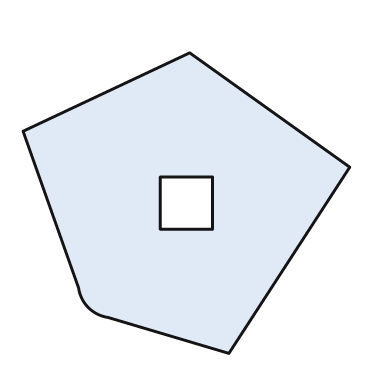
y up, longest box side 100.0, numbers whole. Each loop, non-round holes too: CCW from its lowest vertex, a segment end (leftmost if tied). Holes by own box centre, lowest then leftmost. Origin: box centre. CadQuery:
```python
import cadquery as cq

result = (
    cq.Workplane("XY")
    .moveTo(13.0, -46.0)
    .lineTo(50.0, 11.0)
    .lineTo(1.0, 46.0)
    .lineTo(-50.0, 22.0)
    .lineTo(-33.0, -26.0)
    .threePointArc((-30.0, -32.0), (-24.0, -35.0))
    .close()
    .moveTo(-8.0, -8.0)
    .lineTo(8.0, -8.0)
    .lineTo(8.0, 8.0)
    .lineTo(-8.0, 8.0)
    .close()
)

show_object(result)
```